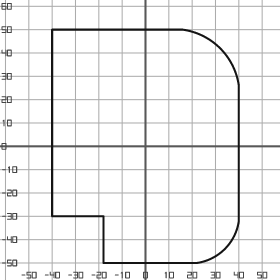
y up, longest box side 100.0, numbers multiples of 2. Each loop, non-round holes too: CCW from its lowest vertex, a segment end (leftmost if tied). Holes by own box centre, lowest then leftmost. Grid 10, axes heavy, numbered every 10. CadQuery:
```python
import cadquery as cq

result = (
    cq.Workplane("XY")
    .moveTo(-18.0, -50.0)
    .lineTo(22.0, -50.0)
    .threePointArc((34.0, -44.0), (40.0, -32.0))
    .lineTo(40.0, 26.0)
    .threePointArc((32.0, 42.0), (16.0, 50.0))
    .lineTo(-40.0, 50.0)
    .lineTo(-40.0, -30.0)
    .lineTo(-18.0, -30.0)
    .close()
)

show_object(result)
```